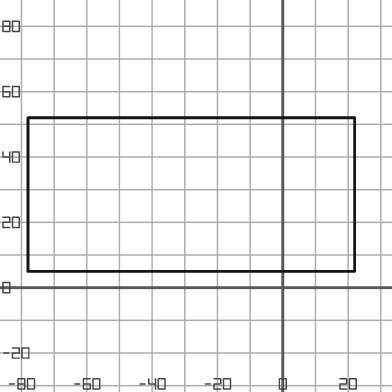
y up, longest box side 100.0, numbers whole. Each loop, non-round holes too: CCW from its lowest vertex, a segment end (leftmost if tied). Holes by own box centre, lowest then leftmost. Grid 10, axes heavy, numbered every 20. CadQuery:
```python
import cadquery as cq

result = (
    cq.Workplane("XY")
    .moveTo(-78.0, 5.0)
    .lineTo(22.0, 5.0)
    .lineTo(22.0, 52.0)
    .lineTo(-78.0, 52.0)
    .close()
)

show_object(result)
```